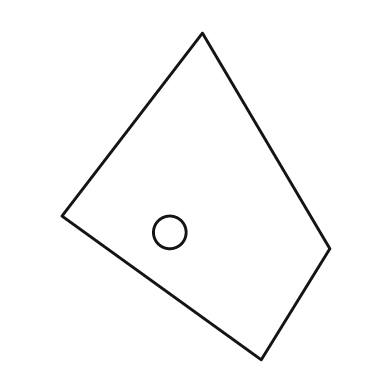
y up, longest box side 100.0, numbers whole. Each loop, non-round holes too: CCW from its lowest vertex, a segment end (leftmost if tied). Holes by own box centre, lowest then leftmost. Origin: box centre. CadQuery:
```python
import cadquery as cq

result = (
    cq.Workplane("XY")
    .moveTo(20.0, -50.0)
    .lineTo(41.0, -16.0)
    .lineTo(2.0, 50.0)
    .lineTo(-41.0, -6.0)
    .close()
    .moveTo(-8.0, -11.0)
    .circle(5.0)
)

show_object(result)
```